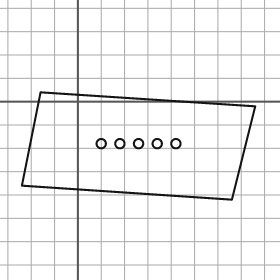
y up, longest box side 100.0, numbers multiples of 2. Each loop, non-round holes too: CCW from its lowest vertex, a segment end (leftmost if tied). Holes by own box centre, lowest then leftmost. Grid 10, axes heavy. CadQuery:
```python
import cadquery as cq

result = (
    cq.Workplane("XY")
    .moveTo(66.0, -42.0)
    .lineTo(76.0, -2.0)
    .lineTo(-16.0, 4.0)
    .lineTo(-24.0, -36.0)
    .close()
    .moveTo(10.0, -18.0)
    .circle(2.0)
    .moveTo(18.0, -18.0)
    .circle(2.0)
    .moveTo(26.0, -18.0)
    .circle(2.0)
    .moveTo(34.0, -18.0)
    .circle(2.0)
    .moveTo(42.0, -18.0)
    .circle(2.0)
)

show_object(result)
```